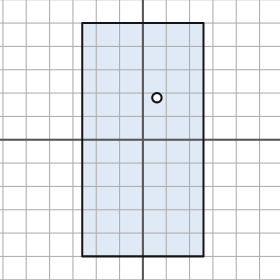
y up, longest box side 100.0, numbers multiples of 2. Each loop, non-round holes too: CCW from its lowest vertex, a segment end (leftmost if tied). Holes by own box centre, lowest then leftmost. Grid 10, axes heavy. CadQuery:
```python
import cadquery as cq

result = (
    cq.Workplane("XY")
    .moveTo(-26.0, -50.0)
    .lineTo(26.0, -50.0)
    .lineTo(26.0, 50.0)
    .lineTo(-26.0, 50.0)
    .close()
    .moveTo(6.0, 18.0)
    .circle(2.0)
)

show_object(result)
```